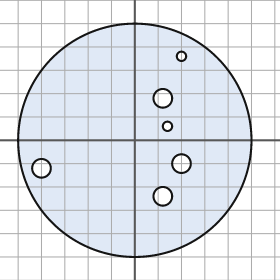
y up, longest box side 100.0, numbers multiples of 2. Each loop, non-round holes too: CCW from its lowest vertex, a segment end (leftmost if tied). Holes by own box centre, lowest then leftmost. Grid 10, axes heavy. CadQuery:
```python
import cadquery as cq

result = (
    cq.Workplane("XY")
    .moveTo(0.0, 0.0)
    .circle(50.0)
    .moveTo(12.0, -24.0)
    .circle(4.0)
    .moveTo(-40.0, -12.0)
    .circle(4.0)
    .moveTo(20.0, -10.0)
    .circle(4.0)
    .moveTo(14.0, 6.0)
    .circle(2.0)
    .moveTo(12.0, 18.0)
    .circle(4.0)
    .moveTo(20.0, 36.0)
    .circle(2.0)
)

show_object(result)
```